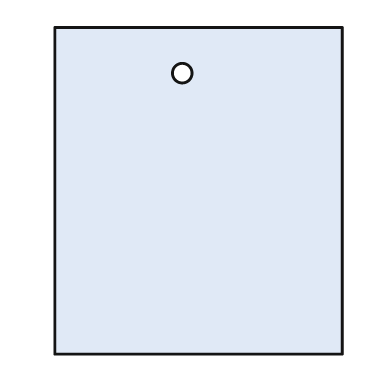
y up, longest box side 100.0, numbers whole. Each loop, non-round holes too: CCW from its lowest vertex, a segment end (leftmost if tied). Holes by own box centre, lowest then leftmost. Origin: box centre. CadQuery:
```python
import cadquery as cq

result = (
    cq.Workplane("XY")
    .moveTo(-44.0, -50.0)
    .lineTo(44.0, -50.0)
    .lineTo(44.0, 50.0)
    .lineTo(-44.0, 50.0)
    .close()
    .moveTo(-5.0, 36.0)
    .circle(3.0)
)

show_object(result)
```